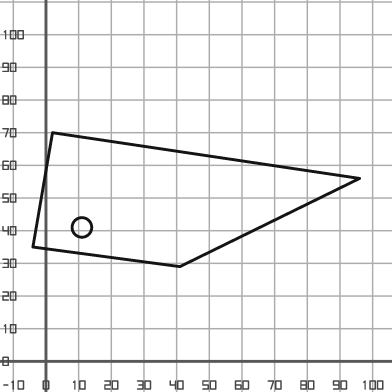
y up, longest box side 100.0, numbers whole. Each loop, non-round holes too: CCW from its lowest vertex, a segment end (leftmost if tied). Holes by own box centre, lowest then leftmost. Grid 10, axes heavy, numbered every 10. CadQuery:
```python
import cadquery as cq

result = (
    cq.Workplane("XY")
    .moveTo(41.0, 29.0)
    .lineTo(96.0, 56.0)
    .lineTo(2.0, 70.0)
    .lineTo(-4.0, 35.0)
    .close()
    .moveTo(11.0, 41.0)
    .circle(3.0)
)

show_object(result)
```